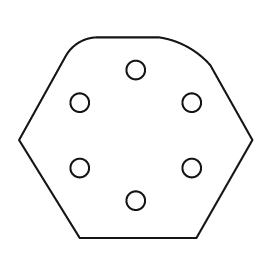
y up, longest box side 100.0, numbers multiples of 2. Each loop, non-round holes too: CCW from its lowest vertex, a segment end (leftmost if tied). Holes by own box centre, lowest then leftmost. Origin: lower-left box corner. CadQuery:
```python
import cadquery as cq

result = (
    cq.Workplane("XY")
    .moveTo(26.0, 0.0)
    .lineTo(76.0, 0.0)
    .lineTo(100.0, 42.0)
    .lineTo(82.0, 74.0)
    .threePointArc((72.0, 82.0), (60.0, 86.0))
    .lineTo(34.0, 86.0)
    .threePointArc((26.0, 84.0), (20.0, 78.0))
    .lineTo(0.0, 42.0)
    .close()
    .moveTo(50.0, 16.0)
    .circle(4.0)
    .moveTo(26.0, 30.0)
    .circle(4.0)
    .moveTo(74.0, 30.0)
    .circle(4.0)
    .moveTo(26.0, 58.0)
    .circle(4.0)
    .moveTo(74.0, 58.0)
    .circle(4.0)
    .moveTo(50.0, 72.0)
    .circle(4.0)
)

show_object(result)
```